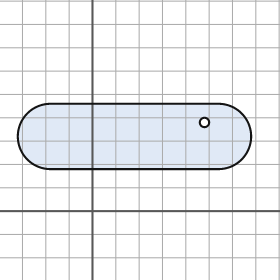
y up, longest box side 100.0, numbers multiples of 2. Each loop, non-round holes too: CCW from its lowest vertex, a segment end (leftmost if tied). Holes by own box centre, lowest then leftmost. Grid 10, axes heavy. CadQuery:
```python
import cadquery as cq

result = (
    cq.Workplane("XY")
    .moveTo(-18.0, 18.0)
    .lineTo(54.0, 18.0)
    .threePointArc((68.0, 32.0), (54.0, 46.0))
    .lineTo(-18.0, 46.0)
    .threePointArc((-32.0, 32.0), (-18.0, 18.0))
    .close()
    .moveTo(48.0, 38.0)
    .circle(2.0)
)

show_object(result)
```